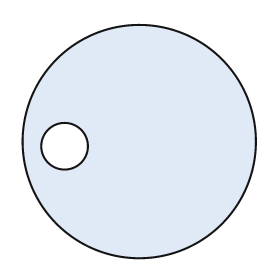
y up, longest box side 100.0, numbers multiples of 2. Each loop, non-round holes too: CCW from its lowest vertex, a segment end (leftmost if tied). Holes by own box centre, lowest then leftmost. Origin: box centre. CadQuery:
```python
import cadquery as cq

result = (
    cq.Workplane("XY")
    .moveTo(0.0, 0.0)
    .circle(50.0)
    .moveTo(-32.0, -2.0)
    .circle(10.0)
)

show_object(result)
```